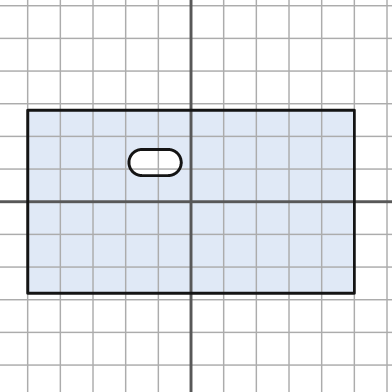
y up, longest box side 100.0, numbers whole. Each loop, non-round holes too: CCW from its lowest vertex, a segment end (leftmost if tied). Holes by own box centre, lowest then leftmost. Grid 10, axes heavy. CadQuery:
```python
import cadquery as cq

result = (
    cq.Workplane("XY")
    .moveTo(-50.0, -28.0)
    .lineTo(50.0, -28.0)
    .lineTo(50.0, 28.0)
    .lineTo(-50.0, 28.0)
    .close()
    .moveTo(-15.0, 8.0)
    .lineTo(-7.0, 8.0)
    .threePointArc((-3.0, 12.0), (-7.0, 16.0))
    .lineTo(-15.0, 16.0)
    .threePointArc((-19.0, 12.0), (-15.0, 8.0))
    .close()
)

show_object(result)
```